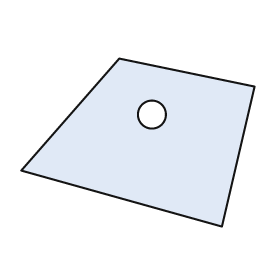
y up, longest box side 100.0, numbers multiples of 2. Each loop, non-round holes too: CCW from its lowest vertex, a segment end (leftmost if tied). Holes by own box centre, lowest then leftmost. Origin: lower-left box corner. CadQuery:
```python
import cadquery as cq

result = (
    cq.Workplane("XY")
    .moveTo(86.0, 0.0)
    .lineTo(100.0, 60.0)
    .lineTo(42.0, 72.0)
    .lineTo(0.0, 24.0)
    .close()
    .moveTo(56.0, 48.0)
    .circle(6.0)
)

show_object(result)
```